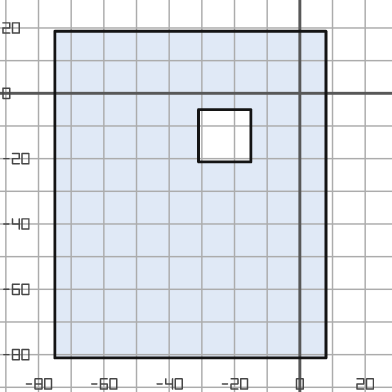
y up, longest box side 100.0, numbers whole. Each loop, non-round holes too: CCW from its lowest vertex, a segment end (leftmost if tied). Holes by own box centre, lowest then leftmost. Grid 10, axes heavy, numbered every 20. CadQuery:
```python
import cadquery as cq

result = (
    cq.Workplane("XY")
    .moveTo(-75.0, -81.0)
    .lineTo(8.0, -81.0)
    .lineTo(8.0, 19.0)
    .lineTo(-75.0, 19.0)
    .close()
    .moveTo(-31.0, -21.0)
    .lineTo(-15.0, -21.0)
    .lineTo(-15.0, -5.0)
    .lineTo(-31.0, -5.0)
    .close()
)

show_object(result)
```